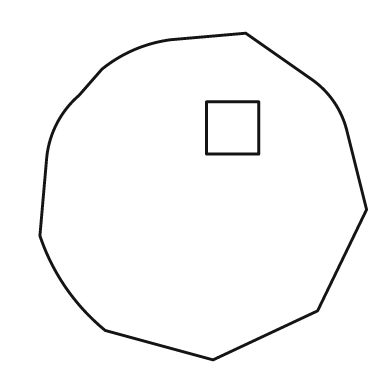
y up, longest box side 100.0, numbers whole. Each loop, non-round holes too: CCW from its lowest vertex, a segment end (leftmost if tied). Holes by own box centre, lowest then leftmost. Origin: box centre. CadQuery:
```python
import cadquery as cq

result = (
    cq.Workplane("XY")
    .moveTo(3.0, -50.0)
    .lineTo(35.0, -35.0)
    .lineTo(50.0, -4.0)
    .lineTo(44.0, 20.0)
    .threePointArc((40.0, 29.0), (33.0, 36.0))
    .lineTo(13.0, 50.0)
    .lineTo(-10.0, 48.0)
    .threePointArc((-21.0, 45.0), (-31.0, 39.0))
    .lineTo(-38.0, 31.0)
    .threePointArc((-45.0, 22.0), (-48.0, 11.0))
    .lineTo(-50.0, -12.0)
    .threePointArc((-42.0, -28.0), (-30.0, -41.0))
    .close()
    .moveTo(1.0, 13.0)
    .lineTo(17.0, 13.0)
    .lineTo(17.0, 29.0)
    .lineTo(1.0, 29.0)
    .close()
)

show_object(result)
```